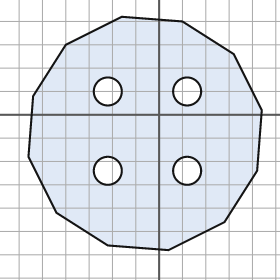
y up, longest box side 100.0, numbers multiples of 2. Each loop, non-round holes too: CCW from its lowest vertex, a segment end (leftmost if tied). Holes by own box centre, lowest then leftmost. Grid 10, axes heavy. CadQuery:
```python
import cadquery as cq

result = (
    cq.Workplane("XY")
    .moveTo(4.0, -58.0)
    .lineTo(28.0, -46.0)
    .lineTo(42.0, -24.0)
    .lineTo(44.0, 2.0)
    .lineTo(32.0, 26.0)
    .lineTo(10.0, 40.0)
    .lineTo(-16.0, 42.0)
    .lineTo(-40.0, 30.0)
    .lineTo(-54.0, 8.0)
    .lineTo(-56.0, -18.0)
    .lineTo(-44.0, -42.0)
    .lineTo(-22.0, -56.0)
    .close()
    .moveTo(-22.0, -24.0)
    .circle(6.0)
    .moveTo(12.0, -24.0)
    .circle(6.0)
    .moveTo(-22.0, 10.0)
    .circle(6.0)
    .moveTo(12.0, 10.0)
    .circle(6.0)
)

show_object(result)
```